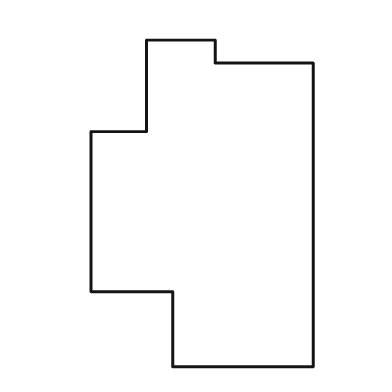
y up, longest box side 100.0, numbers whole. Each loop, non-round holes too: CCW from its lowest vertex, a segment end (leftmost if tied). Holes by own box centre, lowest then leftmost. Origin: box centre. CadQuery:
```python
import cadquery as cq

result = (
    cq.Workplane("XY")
    .moveTo(-9.0, -50.0)
    .lineTo(34.0, -50.0)
    .lineTo(34.0, 43.0)
    .lineTo(4.0, 43.0)
    .lineTo(4.0, 50.0)
    .lineTo(-17.0, 50.0)
    .lineTo(-17.0, 22.0)
    .lineTo(-34.0, 22.0)
    .lineTo(-34.0, -27.0)
    .lineTo(-9.0, -27.0)
    .close()
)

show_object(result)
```